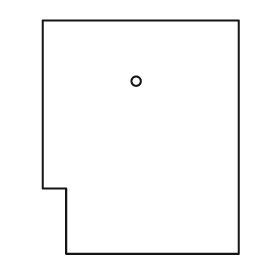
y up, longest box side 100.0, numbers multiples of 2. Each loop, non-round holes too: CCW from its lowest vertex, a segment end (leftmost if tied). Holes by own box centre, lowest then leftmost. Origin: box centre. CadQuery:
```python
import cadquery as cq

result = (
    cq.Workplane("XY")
    .moveTo(-32.0, -50.0)
    .lineTo(42.0, -50.0)
    .lineTo(42.0, 50.0)
    .lineTo(-42.0, 50.0)
    .lineTo(-42.0, -22.0)
    .lineTo(-32.0, -22.0)
    .close()
    .moveTo(-2.0, 24.0)
    .circle(2.0)
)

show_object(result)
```